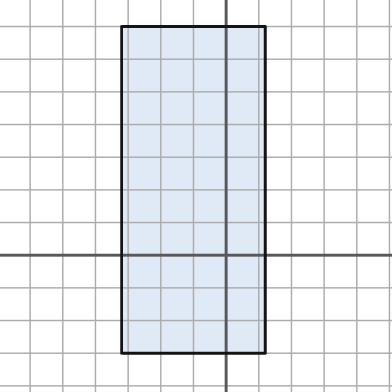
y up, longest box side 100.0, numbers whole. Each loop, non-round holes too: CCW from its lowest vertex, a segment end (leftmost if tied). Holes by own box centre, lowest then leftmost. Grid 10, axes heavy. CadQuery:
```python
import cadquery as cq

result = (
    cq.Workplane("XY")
    .moveTo(-32.0, -30.0)
    .lineTo(12.0, -30.0)
    .lineTo(12.0, 70.0)
    .lineTo(-32.0, 70.0)
    .close()
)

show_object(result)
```